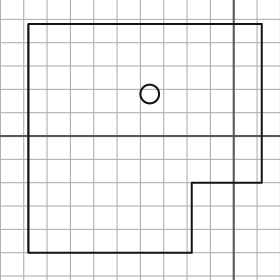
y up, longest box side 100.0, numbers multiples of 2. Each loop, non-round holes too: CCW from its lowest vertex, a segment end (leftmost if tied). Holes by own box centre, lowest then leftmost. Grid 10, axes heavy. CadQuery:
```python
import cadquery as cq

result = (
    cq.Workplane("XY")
    .moveTo(-88.0, -50.0)
    .lineTo(-18.0, -50.0)
    .lineTo(-18.0, -20.0)
    .lineTo(12.0, -20.0)
    .lineTo(12.0, 48.0)
    .lineTo(-88.0, 48.0)
    .close()
    .moveTo(-36.0, 18.0)
    .circle(4.0)
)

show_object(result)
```